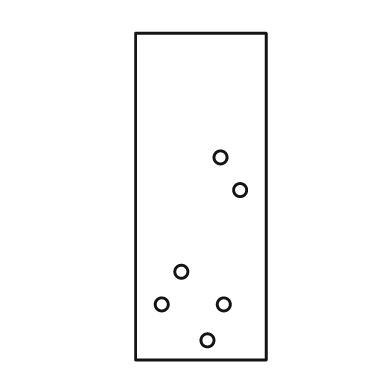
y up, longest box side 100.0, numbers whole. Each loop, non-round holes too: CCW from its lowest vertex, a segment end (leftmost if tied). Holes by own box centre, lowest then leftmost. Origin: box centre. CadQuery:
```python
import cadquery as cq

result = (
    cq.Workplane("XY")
    .moveTo(-20.0, -50.0)
    .lineTo(20.0, -50.0)
    .lineTo(20.0, 50.0)
    .lineTo(-20.0, 50.0)
    .close()
    .moveTo(2.0, -44.0)
    .circle(2.0)
    .moveTo(-12.0, -33.0)
    .circle(2.0)
    .moveTo(7.0, -33.0)
    .circle(2.0)
    .moveTo(-6.0, -23.0)
    .circle(2.0)
    .moveTo(12.0, 2.0)
    .circle(2.0)
    .moveTo(6.0, 12.0)
    .circle(2.0)
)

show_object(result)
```